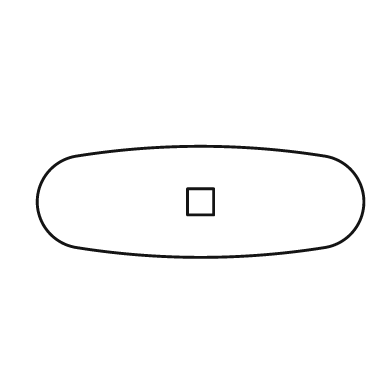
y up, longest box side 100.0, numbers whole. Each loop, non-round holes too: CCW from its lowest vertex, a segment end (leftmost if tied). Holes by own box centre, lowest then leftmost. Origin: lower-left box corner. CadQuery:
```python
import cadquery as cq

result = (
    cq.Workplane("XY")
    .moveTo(12.0, 3.0)
    .threePointArc((50.0, 0.0), (88.0, 3.0))
    .threePointArc((100.0, 17.0), (88.0, 31.0))
    .threePointArc((50.0, 34.0), (12.0, 31.0))
    .threePointArc((0.0, 17.0), (12.0, 3.0))
    .close()
    .moveTo(46.0, 13.0)
    .lineTo(54.0, 13.0)
    .lineTo(54.0, 21.0)
    .lineTo(46.0, 21.0)
    .close()
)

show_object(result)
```